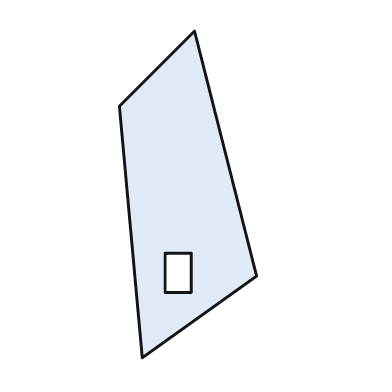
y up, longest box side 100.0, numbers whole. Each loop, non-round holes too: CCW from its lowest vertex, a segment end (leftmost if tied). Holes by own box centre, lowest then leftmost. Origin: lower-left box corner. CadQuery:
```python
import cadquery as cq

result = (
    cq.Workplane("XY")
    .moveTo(7.0, 0.0)
    .lineTo(42.0, 25.0)
    .lineTo(23.0, 100.0)
    .lineTo(0.0, 77.0)
    .close()
    .moveTo(14.0, 20.0)
    .lineTo(22.0, 20.0)
    .lineTo(22.0, 32.0)
    .lineTo(14.0, 32.0)
    .close()
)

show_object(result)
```